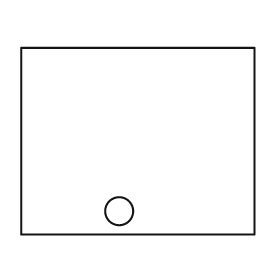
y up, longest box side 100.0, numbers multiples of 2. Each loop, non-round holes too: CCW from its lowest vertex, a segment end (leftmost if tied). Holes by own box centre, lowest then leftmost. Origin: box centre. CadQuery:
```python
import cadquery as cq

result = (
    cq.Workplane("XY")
    .moveTo(-50.0, -40.0)
    .lineTo(50.0, -40.0)
    .lineTo(50.0, 40.0)
    .lineTo(-50.0, 40.0)
    .close()
    .moveTo(-8.0, -30.0)
    .circle(6.0)
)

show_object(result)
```